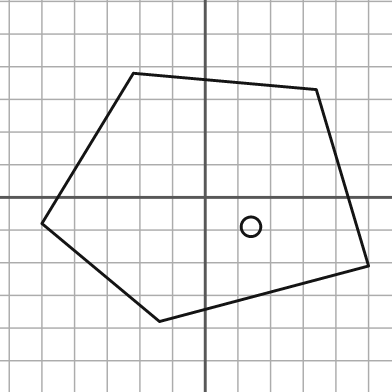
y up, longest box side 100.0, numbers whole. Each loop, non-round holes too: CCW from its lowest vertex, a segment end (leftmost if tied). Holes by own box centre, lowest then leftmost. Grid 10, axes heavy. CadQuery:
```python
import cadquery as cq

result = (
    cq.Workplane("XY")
    .moveTo(-14.0, -38.0)
    .lineTo(50.0, -21.0)
    .lineTo(34.0, 33.0)
    .lineTo(-22.0, 38.0)
    .lineTo(-50.0, -8.0)
    .close()
    .moveTo(14.0, -9.0)
    .circle(3.0)
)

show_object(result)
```